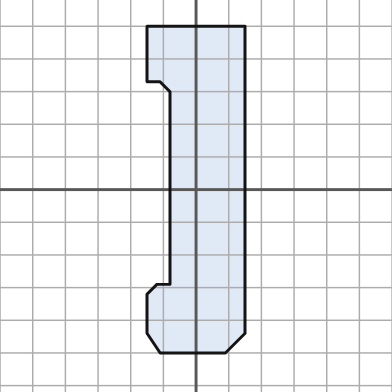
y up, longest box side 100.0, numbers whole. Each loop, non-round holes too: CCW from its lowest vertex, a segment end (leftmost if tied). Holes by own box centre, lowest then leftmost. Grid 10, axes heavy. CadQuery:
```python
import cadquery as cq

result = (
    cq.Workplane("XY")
    .moveTo(-11.0, -50.0)
    .lineTo(9.0, -50.0)
    .lineTo(15.0, -44.0)
    .lineTo(15.0, 50.0)
    .lineTo(-15.0, 50.0)
    .lineTo(-15.0, 33.0)
    .lineTo(-11.0, 33.0)
    .lineTo(-8.0, 30.0)
    .lineTo(-8.0, -29.0)
    .lineTo(-12.0, -29.0)
    .lineTo(-15.0, -32.0)
    .lineTo(-15.0, -44.0)
    .close()
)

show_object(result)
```